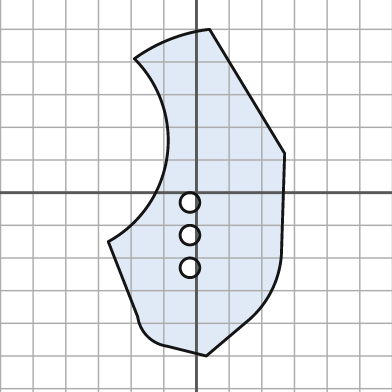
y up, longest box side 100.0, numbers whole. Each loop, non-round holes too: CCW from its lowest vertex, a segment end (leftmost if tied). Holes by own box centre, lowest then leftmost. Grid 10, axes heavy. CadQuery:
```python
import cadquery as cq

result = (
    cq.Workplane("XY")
    .moveTo(3.0, -50.0)
    .lineTo(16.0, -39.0)
    .threePointArc((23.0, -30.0), (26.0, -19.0))
    .lineTo(27.0, 12.0)
    .lineTo(4.0, 50.0)
    .threePointArc((-8.0, 47.0), (-19.0, 41.0))
    .threePointArc((-9.0, 11.0), (-27.0, -15.0))
    .lineTo(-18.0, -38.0)
    .threePointArc((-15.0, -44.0), (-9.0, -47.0))
    .close()
    .moveTo(-2.0, -23.0)
    .circle(3.0)
    .moveTo(-2.0, -13.0)
    .circle(3.0)
    .moveTo(-2.0, -3.0)
    .circle(3.0)
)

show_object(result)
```